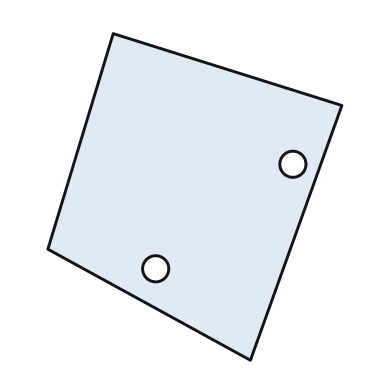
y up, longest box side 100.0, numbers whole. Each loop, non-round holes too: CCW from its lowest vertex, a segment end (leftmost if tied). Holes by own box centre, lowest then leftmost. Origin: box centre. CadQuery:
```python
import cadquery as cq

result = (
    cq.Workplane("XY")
    .moveTo(17.0, -50.0)
    .lineTo(45.0, 28.0)
    .lineTo(-25.0, 50.0)
    .lineTo(-45.0, -16.0)
    .close()
    .moveTo(-12.0, -22.0)
    .circle(4.0)
    .moveTo(30.0, 10.0)
    .circle(4.0)
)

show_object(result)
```